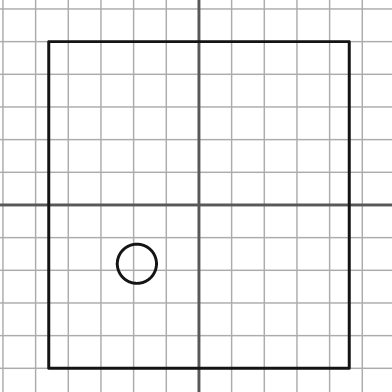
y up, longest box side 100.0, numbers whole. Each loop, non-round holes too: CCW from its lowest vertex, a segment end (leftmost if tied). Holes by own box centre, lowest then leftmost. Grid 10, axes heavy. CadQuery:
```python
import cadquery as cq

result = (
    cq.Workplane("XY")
    .moveTo(-46.0, -50.0)
    .lineTo(46.0, -50.0)
    .lineTo(46.0, 50.0)
    .lineTo(-46.0, 50.0)
    .close()
    .moveTo(-19.0, -18.0)
    .circle(6.0)
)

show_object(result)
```